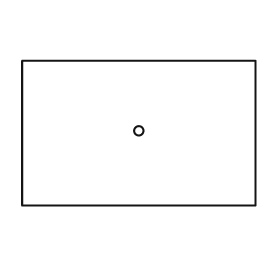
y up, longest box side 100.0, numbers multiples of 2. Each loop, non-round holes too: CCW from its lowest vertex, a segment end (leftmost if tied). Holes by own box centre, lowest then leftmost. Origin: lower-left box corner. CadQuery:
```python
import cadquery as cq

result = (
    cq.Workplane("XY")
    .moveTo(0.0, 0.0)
    .lineTo(100.0, 0.0)
    .lineTo(100.0, 62.0)
    .lineTo(0.0, 62.0)
    .close()
    .moveTo(50.0, 32.0)
    .circle(2.0)
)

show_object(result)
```